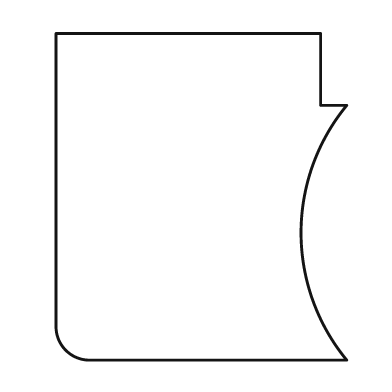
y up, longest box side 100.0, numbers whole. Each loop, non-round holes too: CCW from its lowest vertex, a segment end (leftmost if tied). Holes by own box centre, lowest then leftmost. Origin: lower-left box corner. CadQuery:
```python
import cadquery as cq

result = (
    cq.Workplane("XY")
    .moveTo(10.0, 0.0)
    .lineTo(89.0, 0.0)
    .threePointArc((75.0, 39.0), (89.0, 78.0))
    .lineTo(81.0, 78.0)
    .lineTo(81.0, 100.0)
    .lineTo(0.0, 100.0)
    .lineTo(0.0, 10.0)
    .threePointArc((3.0, 3.0), (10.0, 0.0))
    .close()
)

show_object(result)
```